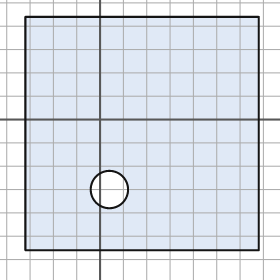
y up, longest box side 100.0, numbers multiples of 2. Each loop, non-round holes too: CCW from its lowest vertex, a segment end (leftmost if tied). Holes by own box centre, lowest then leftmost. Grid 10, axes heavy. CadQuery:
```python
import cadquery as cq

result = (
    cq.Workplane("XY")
    .moveTo(-32.0, -56.0)
    .lineTo(68.0, -56.0)
    .lineTo(68.0, 44.0)
    .lineTo(-32.0, 44.0)
    .close()
    .moveTo(4.0, -30.0)
    .circle(8.0)
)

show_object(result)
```